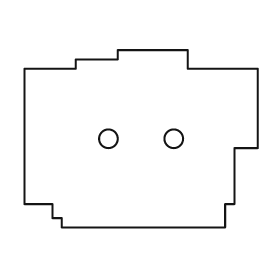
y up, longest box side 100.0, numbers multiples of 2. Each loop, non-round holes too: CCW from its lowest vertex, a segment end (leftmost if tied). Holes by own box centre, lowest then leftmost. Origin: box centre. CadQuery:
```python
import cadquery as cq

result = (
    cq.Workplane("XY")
    .moveTo(-34.0, -38.0)
    .lineTo(36.0, -38.0)
    .lineTo(36.0, -28.0)
    .lineTo(40.0, -28.0)
    .lineTo(40.0, -4.0)
    .lineTo(50.0, -4.0)
    .lineTo(50.0, 30.0)
    .lineTo(20.0, 30.0)
    .lineTo(20.0, 38.0)
    .lineTo(-10.0, 38.0)
    .lineTo(-10.0, 34.0)
    .lineTo(-28.0, 34.0)
    .lineTo(-28.0, 30.0)
    .lineTo(-50.0, 30.0)
    .lineTo(-50.0, -28.0)
    .lineTo(-38.0, -28.0)
    .lineTo(-38.0, -34.0)
    .lineTo(-34.0, -34.0)
    .close()
    .moveTo(-14.0, 0.0)
    .circle(4.0)
    .moveTo(14.0, 0.0)
    .circle(4.0)
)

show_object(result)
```